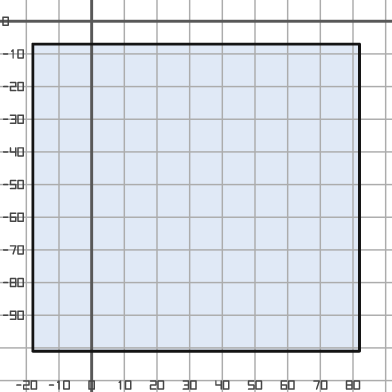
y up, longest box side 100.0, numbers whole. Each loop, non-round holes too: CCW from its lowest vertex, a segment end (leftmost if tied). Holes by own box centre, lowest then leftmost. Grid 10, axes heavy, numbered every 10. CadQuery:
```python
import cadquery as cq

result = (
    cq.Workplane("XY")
    .moveTo(-18.0, -101.0)
    .lineTo(82.0, -101.0)
    .lineTo(82.0, -7.0)
    .lineTo(-18.0, -7.0)
    .close()
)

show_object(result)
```